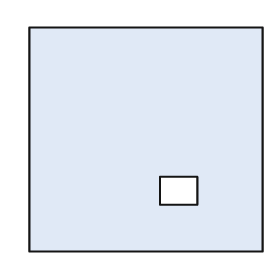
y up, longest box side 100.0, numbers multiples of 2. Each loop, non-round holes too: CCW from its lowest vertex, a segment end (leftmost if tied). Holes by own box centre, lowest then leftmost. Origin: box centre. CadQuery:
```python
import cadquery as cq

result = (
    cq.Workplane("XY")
    .moveTo(-50.0, -48.0)
    .lineTo(50.0, -48.0)
    .lineTo(50.0, 48.0)
    .lineTo(-50.0, 48.0)
    .close()
    .moveTo(6.0, -28.0)
    .lineTo(22.0, -28.0)
    .lineTo(22.0, -16.0)
    .lineTo(6.0, -16.0)
    .close()
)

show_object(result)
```